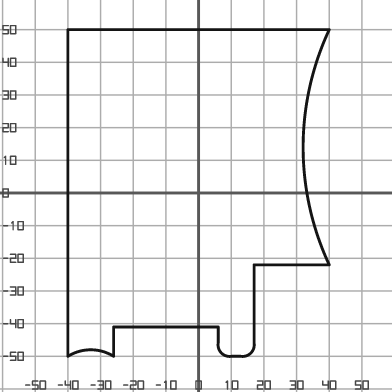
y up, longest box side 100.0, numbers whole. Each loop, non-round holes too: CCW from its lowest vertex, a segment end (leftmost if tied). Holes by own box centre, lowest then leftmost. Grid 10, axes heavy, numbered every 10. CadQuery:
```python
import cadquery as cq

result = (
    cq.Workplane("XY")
    .moveTo(-40.0, -50.0)
    .threePointArc((-33.0, -48.0), (-26.0, -50.0))
    .lineTo(-26.0, -41.0)
    .lineTo(6.0, -41.0)
    .lineTo(6.0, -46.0)
    .threePointArc((7.0, -49.0), (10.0, -50.0))
    .lineTo(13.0, -50.0)
    .threePointArc((16.0, -49.0), (17.0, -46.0))
    .lineTo(17.0, -22.0)
    .lineTo(40.0, -22.0)
    .threePointArc((32.0, 14.0), (40.0, 50.0))
    .lineTo(-40.0, 50.0)
    .close()
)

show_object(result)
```